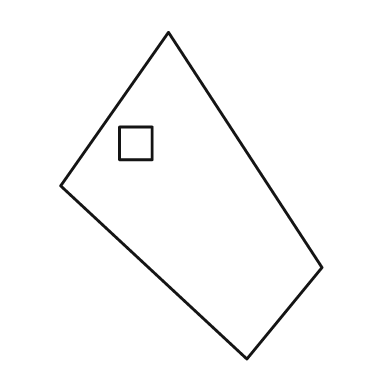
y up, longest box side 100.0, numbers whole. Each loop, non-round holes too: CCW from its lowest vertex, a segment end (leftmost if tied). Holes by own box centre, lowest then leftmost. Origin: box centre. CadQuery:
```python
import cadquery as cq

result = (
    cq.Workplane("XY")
    .moveTo(17.0, -50.0)
    .lineTo(40.0, -22.0)
    .lineTo(-7.0, 50.0)
    .lineTo(-40.0, 3.0)
    .close()
    .moveTo(-22.0, 11.0)
    .lineTo(-12.0, 11.0)
    .lineTo(-12.0, 21.0)
    .lineTo(-22.0, 21.0)
    .close()
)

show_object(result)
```